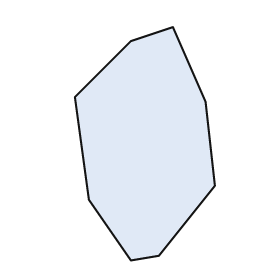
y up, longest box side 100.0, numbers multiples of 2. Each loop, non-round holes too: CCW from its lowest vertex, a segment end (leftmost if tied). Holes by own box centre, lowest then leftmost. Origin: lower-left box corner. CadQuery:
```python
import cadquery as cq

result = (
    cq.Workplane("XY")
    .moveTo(24.0, 0.0)
    .lineTo(36.0, 2.0)
    .lineTo(60.0, 32.0)
    .lineTo(56.0, 68.0)
    .lineTo(42.0, 100.0)
    .lineTo(24.0, 94.0)
    .lineTo(0.0, 70.0)
    .lineTo(6.0, 26.0)
    .close()
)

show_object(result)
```